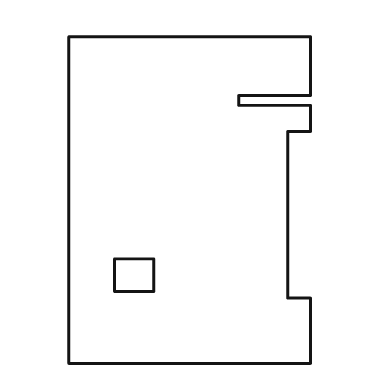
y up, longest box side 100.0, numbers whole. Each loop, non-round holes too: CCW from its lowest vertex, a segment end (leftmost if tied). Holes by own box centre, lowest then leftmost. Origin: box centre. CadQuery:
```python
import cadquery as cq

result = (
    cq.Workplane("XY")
    .moveTo(-37.0, -50.0)
    .lineTo(37.0, -50.0)
    .lineTo(37.0, -30.0)
    .lineTo(30.0, -30.0)
    .lineTo(30.0, 21.0)
    .lineTo(37.0, 21.0)
    .lineTo(37.0, 29.0)
    .lineTo(15.0, 29.0)
    .lineTo(15.0, 32.0)
    .lineTo(37.0, 32.0)
    .lineTo(37.0, 50.0)
    .lineTo(-37.0, 50.0)
    .close()
    .moveTo(-23.0, -28.0)
    .lineTo(-11.0, -28.0)
    .lineTo(-11.0, -18.0)
    .lineTo(-23.0, -18.0)
    .close()
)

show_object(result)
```